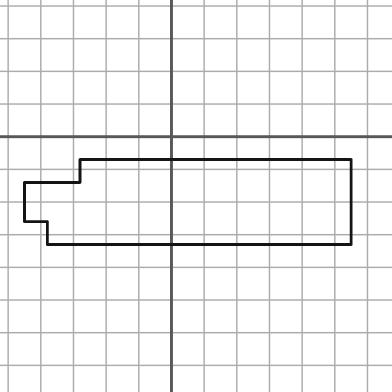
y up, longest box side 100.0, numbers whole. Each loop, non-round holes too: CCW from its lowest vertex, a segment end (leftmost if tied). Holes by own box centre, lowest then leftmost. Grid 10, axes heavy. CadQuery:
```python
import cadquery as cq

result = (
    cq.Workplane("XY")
    .moveTo(-38.0, -33.0)
    .lineTo(55.0, -33.0)
    .lineTo(55.0, -7.0)
    .lineTo(-28.0, -7.0)
    .lineTo(-28.0, -14.0)
    .lineTo(-45.0, -14.0)
    .lineTo(-45.0, -26.0)
    .lineTo(-38.0, -26.0)
    .close()
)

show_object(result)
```